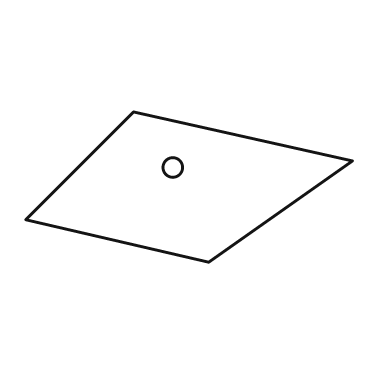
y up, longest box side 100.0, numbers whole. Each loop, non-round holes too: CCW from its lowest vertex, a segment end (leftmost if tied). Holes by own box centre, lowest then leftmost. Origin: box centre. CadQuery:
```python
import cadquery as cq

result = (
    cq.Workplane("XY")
    .moveTo(6.0, -23.0)
    .lineTo(50.0, 8.0)
    .lineTo(-17.0, 23.0)
    .lineTo(-50.0, -10.0)
    .close()
    .moveTo(-5.0, 6.0)
    .circle(3.0)
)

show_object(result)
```